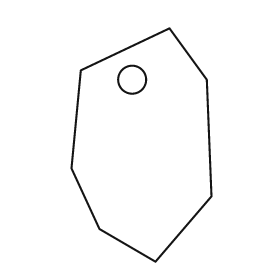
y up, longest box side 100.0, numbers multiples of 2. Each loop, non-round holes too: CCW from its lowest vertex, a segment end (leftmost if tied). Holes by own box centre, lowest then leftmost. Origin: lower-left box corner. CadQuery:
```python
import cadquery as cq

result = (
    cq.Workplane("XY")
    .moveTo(36.0, 0.0)
    .lineTo(60.0, 28.0)
    .lineTo(58.0, 78.0)
    .lineTo(42.0, 100.0)
    .lineTo(4.0, 82.0)
    .lineTo(0.0, 40.0)
    .lineTo(12.0, 14.0)
    .close()
    .moveTo(26.0, 78.0)
    .circle(6.0)
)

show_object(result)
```